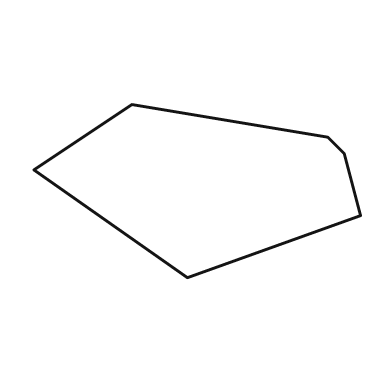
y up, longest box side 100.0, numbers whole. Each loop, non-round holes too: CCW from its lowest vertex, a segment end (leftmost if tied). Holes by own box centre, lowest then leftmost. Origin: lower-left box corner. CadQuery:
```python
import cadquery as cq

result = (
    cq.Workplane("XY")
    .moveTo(47.0, 0.0)
    .lineTo(100.0, 19.0)
    .lineTo(95.0, 38.0)
    .lineTo(90.0, 43.0)
    .lineTo(30.0, 53.0)
    .lineTo(0.0, 33.0)
    .close()
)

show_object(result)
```